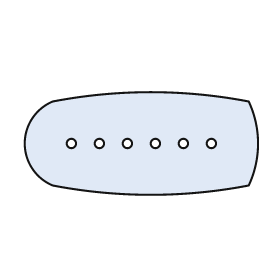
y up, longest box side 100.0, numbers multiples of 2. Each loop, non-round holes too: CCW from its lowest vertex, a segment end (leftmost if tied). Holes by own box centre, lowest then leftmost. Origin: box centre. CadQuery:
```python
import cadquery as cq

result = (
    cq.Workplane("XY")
    .moveTo(-38.0, -18.0)
    .threePointArc((4.0, -22.0), (46.0, -18.0))
    .threePointArc((50.0, 0.0), (46.0, 18.0))
    .threePointArc((4.0, 22.0), (-38.0, 18.0))
    .threePointArc((-50.0, 0.0), (-38.0, -18.0))
    .close()
    .moveTo(-30.0, 0.0)
    .circle(2.0)
    .moveTo(-18.0, 0.0)
    .circle(2.0)
    .moveTo(-6.0, 0.0)
    .circle(2.0)
    .moveTo(6.0, 0.0)
    .circle(2.0)
    .moveTo(18.0, 0.0)
    .circle(2.0)
    .moveTo(30.0, 0.0)
    .circle(2.0)
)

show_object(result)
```